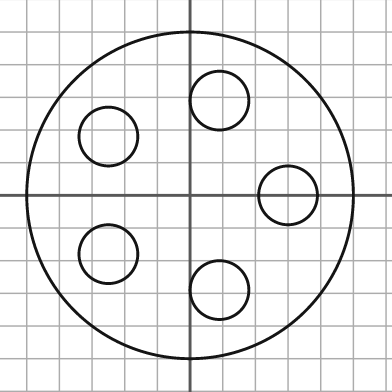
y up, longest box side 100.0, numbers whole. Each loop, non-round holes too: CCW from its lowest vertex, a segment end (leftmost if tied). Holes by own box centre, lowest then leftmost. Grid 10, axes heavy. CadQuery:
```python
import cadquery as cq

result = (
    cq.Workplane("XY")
    .moveTo(0.0, 0.0)
    .circle(50.0)
    .moveTo(9.0, -29.0)
    .circle(9.0)
    .moveTo(-25.0, -18.0)
    .circle(9.0)
    .moveTo(30.0, 0.0)
    .circle(9.0)
    .moveTo(-25.0, 18.0)
    .circle(9.0)
    .moveTo(9.0, 29.0)
    .circle(9.0)
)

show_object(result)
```